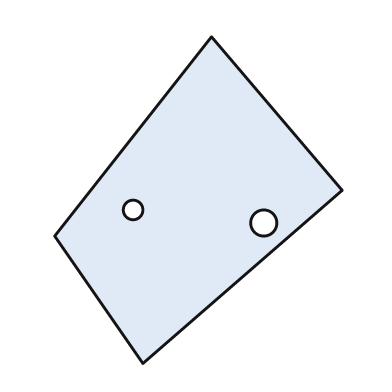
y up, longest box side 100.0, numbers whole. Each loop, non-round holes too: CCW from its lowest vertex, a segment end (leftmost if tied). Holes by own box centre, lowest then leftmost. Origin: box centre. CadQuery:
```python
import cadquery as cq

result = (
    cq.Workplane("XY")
    .moveTo(-17.0, -50.0)
    .lineTo(44.0, 3.0)
    .lineTo(4.0, 50.0)
    .lineTo(-44.0, -11.0)
    .close()
    .moveTo(20.0, -7.0)
    .circle(4.0)
    .moveTo(-20.0, -3.0)
    .circle(3.0)
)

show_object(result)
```